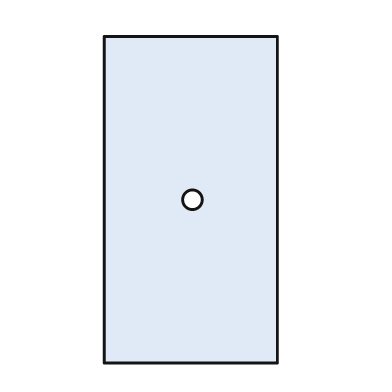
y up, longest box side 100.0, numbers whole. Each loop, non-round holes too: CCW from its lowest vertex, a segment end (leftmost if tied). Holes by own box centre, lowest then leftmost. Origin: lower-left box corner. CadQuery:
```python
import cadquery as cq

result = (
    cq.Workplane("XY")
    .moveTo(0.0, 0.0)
    .lineTo(53.0, 0.0)
    .lineTo(53.0, 100.0)
    .lineTo(0.0, 100.0)
    .close()
    .moveTo(27.0, 50.0)
    .circle(3.0)
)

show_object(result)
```